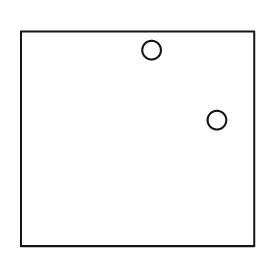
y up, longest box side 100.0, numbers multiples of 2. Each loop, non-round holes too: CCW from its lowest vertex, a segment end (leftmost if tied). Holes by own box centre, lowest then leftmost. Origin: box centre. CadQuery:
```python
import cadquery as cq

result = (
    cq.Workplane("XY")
    .moveTo(-50.0, -46.0)
    .lineTo(50.0, -46.0)
    .lineTo(50.0, 46.0)
    .lineTo(-50.0, 46.0)
    .close()
    .moveTo(34.0, 8.0)
    .circle(4.0)
    .moveTo(6.0, 38.0)
    .circle(4.0)
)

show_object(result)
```